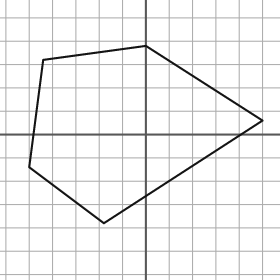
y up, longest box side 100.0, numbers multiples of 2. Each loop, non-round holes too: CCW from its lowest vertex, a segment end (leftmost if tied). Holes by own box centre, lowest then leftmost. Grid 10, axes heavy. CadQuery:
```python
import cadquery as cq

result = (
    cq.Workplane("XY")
    .moveTo(-18.0, -38.0)
    .lineTo(50.0, 6.0)
    .lineTo(0.0, 38.0)
    .lineTo(-44.0, 32.0)
    .lineTo(-50.0, -14.0)
    .close()
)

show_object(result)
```